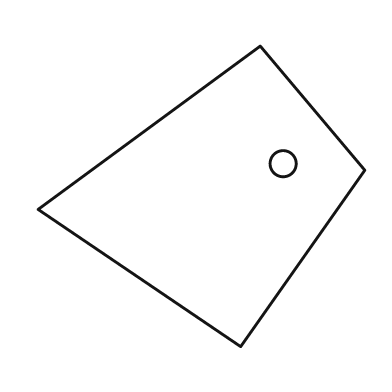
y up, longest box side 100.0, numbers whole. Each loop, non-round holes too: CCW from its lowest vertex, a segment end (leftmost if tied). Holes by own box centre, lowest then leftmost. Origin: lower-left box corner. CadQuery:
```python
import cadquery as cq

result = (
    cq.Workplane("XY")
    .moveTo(62.0, 0.0)
    .lineTo(100.0, 54.0)
    .lineTo(68.0, 92.0)
    .lineTo(0.0, 42.0)
    .close()
    .moveTo(75.0, 56.0)
    .circle(4.0)
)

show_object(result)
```